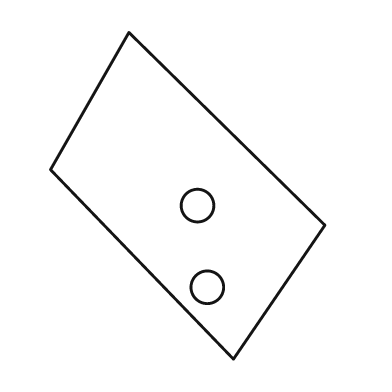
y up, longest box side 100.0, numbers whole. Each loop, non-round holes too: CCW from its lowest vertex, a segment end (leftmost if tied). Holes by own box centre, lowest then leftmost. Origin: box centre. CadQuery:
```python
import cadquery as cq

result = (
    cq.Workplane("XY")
    .moveTo(14.0, -50.0)
    .lineTo(42.0, -9.0)
    .lineTo(-18.0, 50.0)
    .lineTo(-42.0, 8.0)
    .close()
    .moveTo(6.0, -28.0)
    .circle(5.0)
    .moveTo(3.0, -3.0)
    .circle(5.0)
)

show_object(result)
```